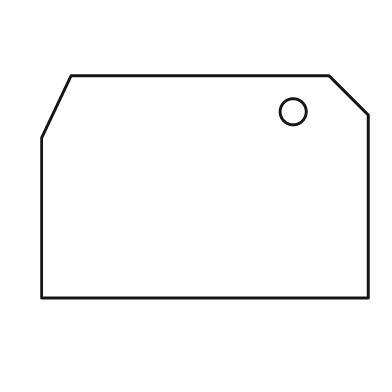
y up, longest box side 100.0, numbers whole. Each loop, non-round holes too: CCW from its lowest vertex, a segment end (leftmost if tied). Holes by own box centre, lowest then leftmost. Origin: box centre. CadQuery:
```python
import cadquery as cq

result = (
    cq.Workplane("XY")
    .moveTo(-50.0, -34.0)
    .lineTo(50.0, -34.0)
    .lineTo(50.0, 22.0)
    .lineTo(38.0, 34.0)
    .lineTo(-41.0, 34.0)
    .lineTo(-50.0, 15.0)
    .close()
    .moveTo(27.0, 23.0)
    .circle(4.0)
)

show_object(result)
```